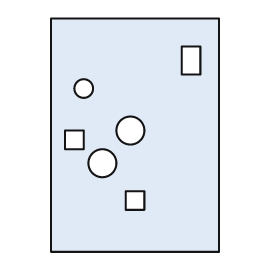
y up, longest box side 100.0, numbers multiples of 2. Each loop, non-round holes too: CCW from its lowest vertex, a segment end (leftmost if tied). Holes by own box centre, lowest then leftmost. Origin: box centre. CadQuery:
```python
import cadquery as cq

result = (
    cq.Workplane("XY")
    .moveTo(-36.0, -50.0)
    .lineTo(36.0, -50.0)
    .lineTo(36.0, 50.0)
    .lineTo(-36.0, 50.0)
    .close()
    .moveTo(-4.0, -32.0)
    .lineTo(4.0, -32.0)
    .lineTo(4.0, -24.0)
    .lineTo(-4.0, -24.0)
    .close()
    .moveTo(-14.0, -12.0)
    .circle(6.0)
    .moveTo(-30.0, -6.0)
    .lineTo(-22.0, -6.0)
    .lineTo(-22.0, 2.0)
    .lineTo(-30.0, 2.0)
    .close()
    .moveTo(-2.0, 2.0)
    .circle(6.0)
    .moveTo(-22.0, 20.0)
    .circle(4.0)
    .moveTo(20.0, 26.0)
    .lineTo(28.0, 26.0)
    .lineTo(28.0, 38.0)
    .lineTo(20.0, 38.0)
    .close()
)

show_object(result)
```